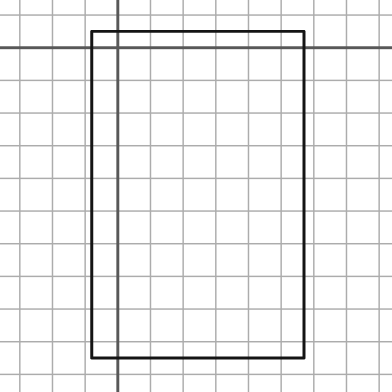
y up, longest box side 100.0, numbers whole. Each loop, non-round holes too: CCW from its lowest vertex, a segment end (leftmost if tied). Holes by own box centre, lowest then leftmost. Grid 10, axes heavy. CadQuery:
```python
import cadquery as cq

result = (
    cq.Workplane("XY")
    .moveTo(-8.0, -95.0)
    .lineTo(57.0, -95.0)
    .lineTo(57.0, 5.0)
    .lineTo(-8.0, 5.0)
    .close()
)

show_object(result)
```